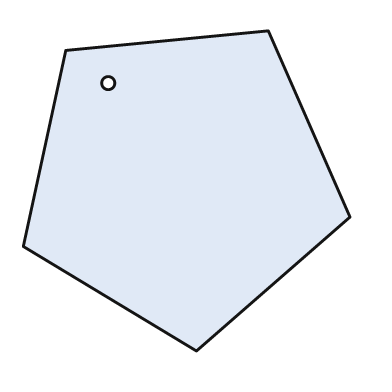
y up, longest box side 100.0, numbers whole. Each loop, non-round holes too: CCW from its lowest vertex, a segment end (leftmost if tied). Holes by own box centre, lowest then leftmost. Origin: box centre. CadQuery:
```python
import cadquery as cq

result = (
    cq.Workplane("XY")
    .moveTo(3.0, -49.0)
    .lineTo(50.0, -8.0)
    .lineTo(25.0, 49.0)
    .lineTo(-37.0, 43.0)
    .lineTo(-50.0, -17.0)
    .close()
    .moveTo(-24.0, 33.0)
    .circle(2.0)
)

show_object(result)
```